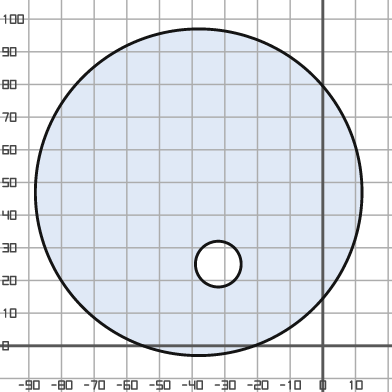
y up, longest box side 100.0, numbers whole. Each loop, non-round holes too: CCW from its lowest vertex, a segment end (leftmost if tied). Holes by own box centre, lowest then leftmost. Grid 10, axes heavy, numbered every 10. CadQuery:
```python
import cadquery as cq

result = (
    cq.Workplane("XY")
    .moveTo(-38.0, 47.0)
    .circle(50.0)
    .moveTo(-32.0, 25.0)
    .circle(7.0)
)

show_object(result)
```